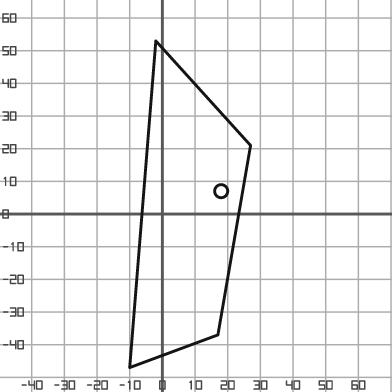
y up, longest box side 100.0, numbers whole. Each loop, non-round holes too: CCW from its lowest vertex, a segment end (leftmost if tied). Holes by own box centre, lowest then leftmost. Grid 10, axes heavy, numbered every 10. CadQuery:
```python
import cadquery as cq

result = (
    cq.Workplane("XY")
    .moveTo(-10.0, -47.0)
    .lineTo(17.0, -37.0)
    .lineTo(27.0, 21.0)
    .lineTo(-2.0, 53.0)
    .close()
    .moveTo(18.0, 7.0)
    .circle(2.0)
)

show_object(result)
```